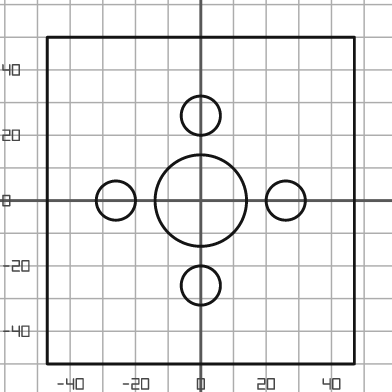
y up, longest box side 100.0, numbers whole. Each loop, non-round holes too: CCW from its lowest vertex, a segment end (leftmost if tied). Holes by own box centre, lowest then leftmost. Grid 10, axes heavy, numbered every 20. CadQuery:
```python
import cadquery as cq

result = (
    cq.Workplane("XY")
    .moveTo(-47.0, -50.0)
    .lineTo(47.0, -50.0)
    .lineTo(47.0, 50.0)
    .lineTo(-47.0, 50.0)
    .close()
    .moveTo(0.0, -26.0)
    .circle(6.0)
    .moveTo(-26.0, 0.0)
    .circle(6.0)
    .moveTo(0.0, 0.0)
    .circle(14.0)
    .moveTo(26.0, 0.0)
    .circle(6.0)
    .moveTo(0.0, 26.0)
    .circle(6.0)
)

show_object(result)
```